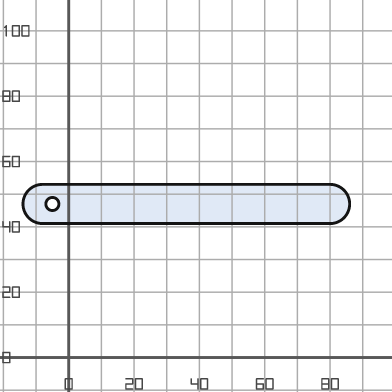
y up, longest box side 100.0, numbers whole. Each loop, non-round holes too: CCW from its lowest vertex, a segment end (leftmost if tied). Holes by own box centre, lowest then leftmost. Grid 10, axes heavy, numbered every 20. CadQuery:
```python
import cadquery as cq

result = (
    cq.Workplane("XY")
    .moveTo(-8.0, 41.0)
    .lineTo(80.0, 41.0)
    .threePointArc((86.0, 47.0), (80.0, 53.0))
    .lineTo(-8.0, 53.0)
    .threePointArc((-14.0, 47.0), (-8.0, 41.0))
    .close()
    .moveTo(-5.0, 47.0)
    .circle(2.0)
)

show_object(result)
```